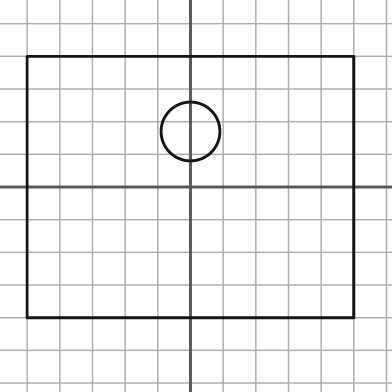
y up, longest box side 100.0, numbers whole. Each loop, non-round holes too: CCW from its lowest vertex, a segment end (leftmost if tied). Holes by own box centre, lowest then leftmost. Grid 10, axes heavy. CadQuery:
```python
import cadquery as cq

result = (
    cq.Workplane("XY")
    .moveTo(-50.0, -40.0)
    .lineTo(50.0, -40.0)
    .lineTo(50.0, 40.0)
    .lineTo(-50.0, 40.0)
    .close()
    .moveTo(0.0, 17.0)
    .circle(9.0)
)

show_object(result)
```